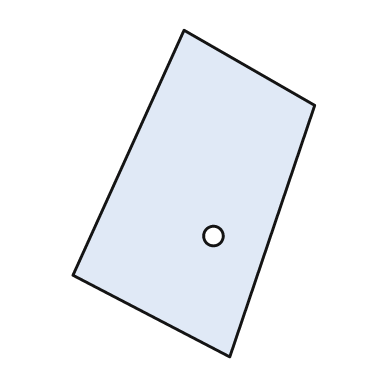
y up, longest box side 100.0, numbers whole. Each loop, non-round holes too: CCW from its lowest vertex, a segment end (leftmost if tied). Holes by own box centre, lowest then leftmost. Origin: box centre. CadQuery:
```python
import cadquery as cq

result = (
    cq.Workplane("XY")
    .moveTo(11.0, -50.0)
    .lineTo(37.0, 27.0)
    .lineTo(-3.0, 50.0)
    .lineTo(-37.0, -25.0)
    .close()
    .moveTo(6.0, -13.0)
    .circle(3.0)
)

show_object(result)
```